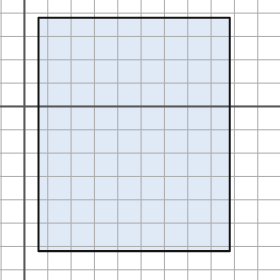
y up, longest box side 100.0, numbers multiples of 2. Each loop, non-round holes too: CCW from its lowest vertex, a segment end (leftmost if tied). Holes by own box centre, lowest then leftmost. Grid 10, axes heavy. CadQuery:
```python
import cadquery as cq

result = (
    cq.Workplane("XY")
    .moveTo(6.0, -62.0)
    .lineTo(88.0, -62.0)
    .lineTo(88.0, 38.0)
    .lineTo(6.0, 38.0)
    .close()
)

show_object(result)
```